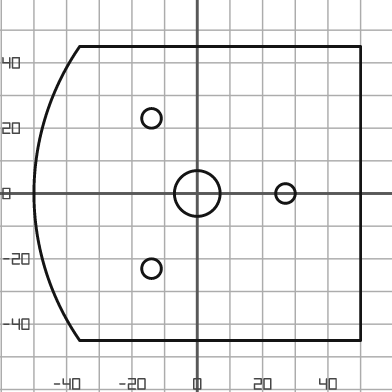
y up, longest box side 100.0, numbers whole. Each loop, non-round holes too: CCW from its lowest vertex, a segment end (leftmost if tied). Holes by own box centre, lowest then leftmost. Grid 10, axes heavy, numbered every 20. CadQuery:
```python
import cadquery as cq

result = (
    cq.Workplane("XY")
    .moveTo(-36.0, -45.0)
    .lineTo(50.0, -45.0)
    .lineTo(50.0, 45.0)
    .lineTo(-36.0, 45.0)
    .threePointArc((-50.0, 0.0), (-36.0, -45.0))
    .close()
    .moveTo(-14.0, -23.0)
    .circle(3.0)
    .moveTo(0.0, 0.0)
    .circle(7.0)
    .moveTo(27.0, 0.0)
    .circle(3.0)
    .moveTo(-14.0, 23.0)
    .circle(3.0)
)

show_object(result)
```